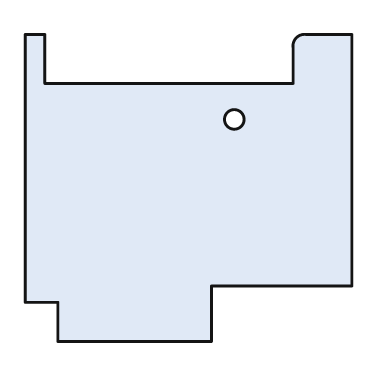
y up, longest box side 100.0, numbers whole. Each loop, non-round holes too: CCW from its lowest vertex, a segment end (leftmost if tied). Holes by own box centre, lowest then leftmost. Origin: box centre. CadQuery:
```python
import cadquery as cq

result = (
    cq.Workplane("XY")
    .moveTo(-40.0, -47.0)
    .lineTo(7.0, -47.0)
    .lineTo(7.0, -30.0)
    .lineTo(50.0, -30.0)
    .lineTo(50.0, 47.0)
    .lineTo(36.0, 47.0)
    .threePointArc((33.0, 46.0), (32.0, 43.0))
    .lineTo(32.0, 32.0)
    .lineTo(-44.0, 32.0)
    .lineTo(-44.0, 47.0)
    .lineTo(-50.0, 47.0)
    .lineTo(-50.0, -35.0)
    .lineTo(-40.0, -35.0)
    .close()
    .moveTo(14.0, 21.0)
    .circle(3.0)
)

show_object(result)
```